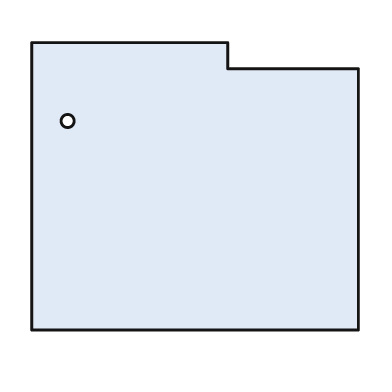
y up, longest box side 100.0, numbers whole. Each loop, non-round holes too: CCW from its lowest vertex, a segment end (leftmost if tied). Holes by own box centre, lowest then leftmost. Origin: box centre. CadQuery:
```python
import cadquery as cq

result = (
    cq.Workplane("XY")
    .moveTo(-50.0, -44.0)
    .lineTo(50.0, -44.0)
    .lineTo(50.0, 36.0)
    .lineTo(10.0, 36.0)
    .lineTo(10.0, 44.0)
    .lineTo(-50.0, 44.0)
    .close()
    .moveTo(-39.0, 20.0)
    .circle(2.0)
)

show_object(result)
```